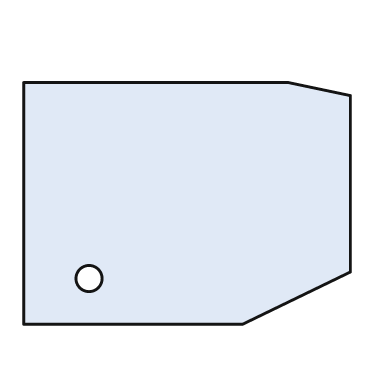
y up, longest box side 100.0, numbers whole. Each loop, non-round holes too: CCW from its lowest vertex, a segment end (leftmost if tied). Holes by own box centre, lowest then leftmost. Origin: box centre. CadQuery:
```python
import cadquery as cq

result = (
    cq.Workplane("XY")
    .moveTo(-50.0, -37.0)
    .lineTo(17.0, -37.0)
    .lineTo(50.0, -21.0)
    .lineTo(50.0, 33.0)
    .lineTo(31.0, 37.0)
    .lineTo(-50.0, 37.0)
    .close()
    .moveTo(-30.0, -23.0)
    .circle(4.0)
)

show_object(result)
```